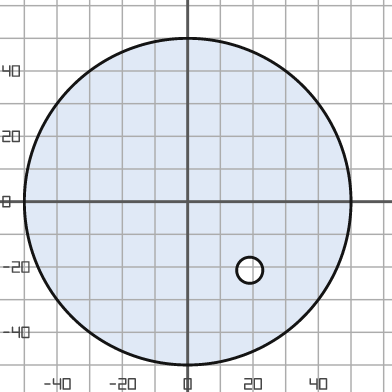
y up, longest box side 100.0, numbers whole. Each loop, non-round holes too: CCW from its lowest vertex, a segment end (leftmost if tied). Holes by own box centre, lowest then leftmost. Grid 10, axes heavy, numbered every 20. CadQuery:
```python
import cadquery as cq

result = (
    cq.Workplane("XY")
    .moveTo(0.0, 0.0)
    .circle(50.0)
    .moveTo(19.0, -21.0)
    .circle(4.0)
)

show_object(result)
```